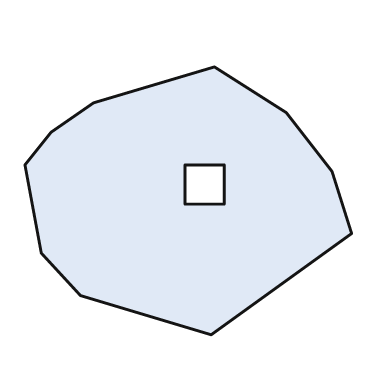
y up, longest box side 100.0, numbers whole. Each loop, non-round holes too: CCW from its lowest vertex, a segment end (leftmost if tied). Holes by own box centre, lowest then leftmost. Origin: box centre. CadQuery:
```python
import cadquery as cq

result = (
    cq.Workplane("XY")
    .moveTo(7.0, -41.0)
    .lineTo(50.0, -10.0)
    .lineTo(44.0, 9.0)
    .lineTo(30.0, 27.0)
    .lineTo(8.0, 41.0)
    .lineTo(-29.0, 30.0)
    .lineTo(-42.0, 21.0)
    .lineTo(-50.0, 11.0)
    .lineTo(-45.0, -16.0)
    .lineTo(-33.0, -29.0)
    .close()
    .moveTo(-1.0, -1.0)
    .lineTo(11.0, -1.0)
    .lineTo(11.0, 11.0)
    .lineTo(-1.0, 11.0)
    .close()
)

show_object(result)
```